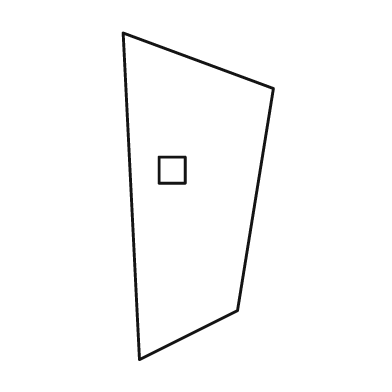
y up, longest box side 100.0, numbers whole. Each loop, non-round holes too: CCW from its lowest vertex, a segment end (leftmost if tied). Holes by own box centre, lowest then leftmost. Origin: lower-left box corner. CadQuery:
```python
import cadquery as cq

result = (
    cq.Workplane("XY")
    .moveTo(5.0, 0.0)
    .lineTo(35.0, 15.0)
    .lineTo(46.0, 83.0)
    .lineTo(0.0, 100.0)
    .close()
    .moveTo(11.0, 54.0)
    .lineTo(19.0, 54.0)
    .lineTo(19.0, 62.0)
    .lineTo(11.0, 62.0)
    .close()
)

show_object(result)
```